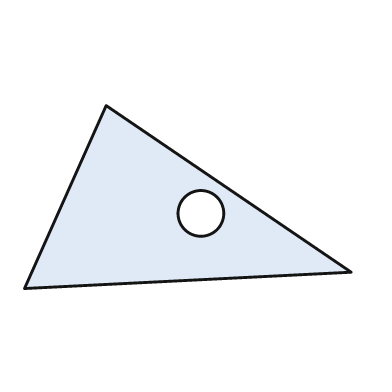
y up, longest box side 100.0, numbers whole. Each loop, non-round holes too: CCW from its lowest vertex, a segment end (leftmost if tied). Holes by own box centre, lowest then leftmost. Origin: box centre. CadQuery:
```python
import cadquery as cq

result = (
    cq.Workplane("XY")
    .moveTo(-50.0, -28.0)
    .lineTo(50.0, -23.0)
    .lineTo(-25.0, 28.0)
    .close()
    .moveTo(4.0, -5.0)
    .circle(7.0)
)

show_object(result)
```